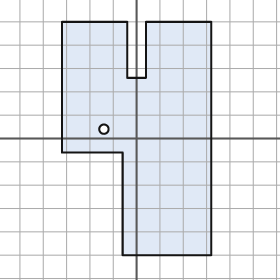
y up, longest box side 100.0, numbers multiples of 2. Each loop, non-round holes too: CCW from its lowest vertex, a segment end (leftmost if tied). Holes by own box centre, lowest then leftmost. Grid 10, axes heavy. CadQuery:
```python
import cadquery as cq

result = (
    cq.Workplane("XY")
    .moveTo(-6.0, -50.0)
    .lineTo(32.0, -50.0)
    .lineTo(32.0, 50.0)
    .lineTo(4.0, 50.0)
    .lineTo(4.0, 26.0)
    .lineTo(-4.0, 26.0)
    .lineTo(-4.0, 50.0)
    .lineTo(-32.0, 50.0)
    .lineTo(-32.0, -6.0)
    .lineTo(-6.0, -6.0)
    .close()
    .moveTo(-14.0, 4.0)
    .circle(2.0)
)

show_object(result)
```